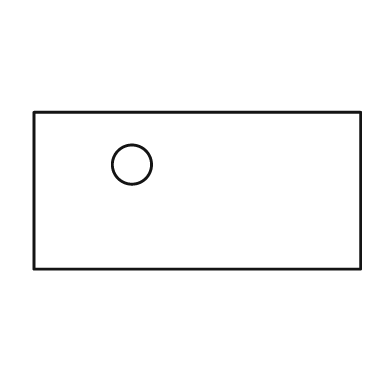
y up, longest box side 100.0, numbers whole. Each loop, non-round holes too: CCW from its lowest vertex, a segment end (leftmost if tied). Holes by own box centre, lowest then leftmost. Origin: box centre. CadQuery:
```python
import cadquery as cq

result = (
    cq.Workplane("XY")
    .moveTo(-50.0, -24.0)
    .lineTo(50.0, -24.0)
    .lineTo(50.0, 24.0)
    .lineTo(-50.0, 24.0)
    .close()
    .moveTo(-20.0, 8.0)
    .circle(6.0)
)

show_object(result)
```